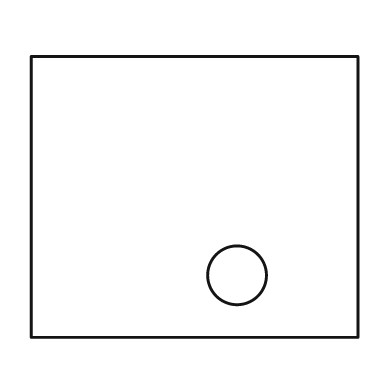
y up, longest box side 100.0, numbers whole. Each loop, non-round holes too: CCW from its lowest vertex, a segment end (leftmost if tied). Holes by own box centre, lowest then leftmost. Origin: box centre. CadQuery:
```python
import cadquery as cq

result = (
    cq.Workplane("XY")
    .moveTo(-50.0, -43.0)
    .lineTo(50.0, -43.0)
    .lineTo(50.0, 43.0)
    .lineTo(-50.0, 43.0)
    .close()
    .moveTo(13.0, -24.0)
    .circle(9.0)
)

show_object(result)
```